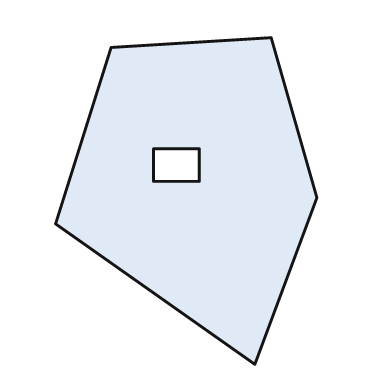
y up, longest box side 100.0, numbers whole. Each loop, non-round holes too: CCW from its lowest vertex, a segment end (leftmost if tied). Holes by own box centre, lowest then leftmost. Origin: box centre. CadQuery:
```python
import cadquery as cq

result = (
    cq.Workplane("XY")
    .moveTo(21.0, -50.0)
    .lineTo(40.0, 1.0)
    .lineTo(26.0, 50.0)
    .lineTo(-23.0, 47.0)
    .lineTo(-40.0, -7.0)
    .close()
    .moveTo(-10.0, 6.0)
    .lineTo(4.0, 6.0)
    .lineTo(4.0, 16.0)
    .lineTo(-10.0, 16.0)
    .close()
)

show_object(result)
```